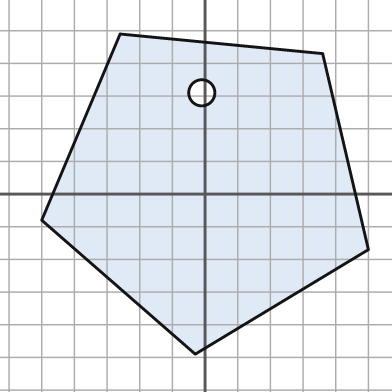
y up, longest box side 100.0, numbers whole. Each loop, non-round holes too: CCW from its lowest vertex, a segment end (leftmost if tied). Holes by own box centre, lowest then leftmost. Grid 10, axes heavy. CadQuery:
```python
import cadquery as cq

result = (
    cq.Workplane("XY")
    .moveTo(-3.0, -49.0)
    .lineTo(50.0, -17.0)
    .lineTo(36.0, 43.0)
    .lineTo(-26.0, 49.0)
    .lineTo(-50.0, -8.0)
    .close()
    .moveTo(-1.0, 31.0)
    .circle(4.0)
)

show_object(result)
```